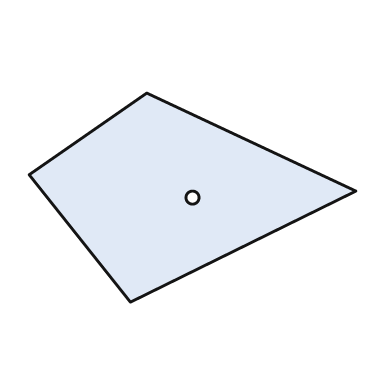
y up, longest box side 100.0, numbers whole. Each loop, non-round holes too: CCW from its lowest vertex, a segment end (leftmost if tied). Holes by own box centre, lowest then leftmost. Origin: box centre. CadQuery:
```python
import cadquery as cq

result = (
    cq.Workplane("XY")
    .moveTo(-19.0, -32.0)
    .lineTo(50.0, 2.0)
    .lineTo(-14.0, 32.0)
    .lineTo(-50.0, 7.0)
    .close()
    .moveTo(0.0, 0.0)
    .circle(2.0)
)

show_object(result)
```